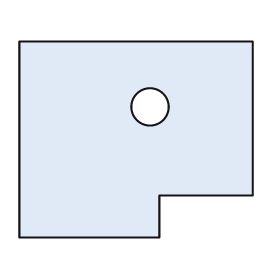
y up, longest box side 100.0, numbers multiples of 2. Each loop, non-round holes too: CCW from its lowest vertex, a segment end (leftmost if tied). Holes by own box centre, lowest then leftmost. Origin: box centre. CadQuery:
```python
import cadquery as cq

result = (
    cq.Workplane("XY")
    .moveTo(-50.0, -42.0)
    .lineTo(10.0, -42.0)
    .lineTo(10.0, -24.0)
    .lineTo(50.0, -24.0)
    .lineTo(50.0, 42.0)
    .lineTo(-50.0, 42.0)
    .close()
    .moveTo(6.0, 14.0)
    .circle(8.0)
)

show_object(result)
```